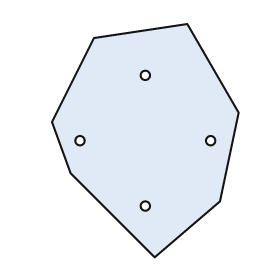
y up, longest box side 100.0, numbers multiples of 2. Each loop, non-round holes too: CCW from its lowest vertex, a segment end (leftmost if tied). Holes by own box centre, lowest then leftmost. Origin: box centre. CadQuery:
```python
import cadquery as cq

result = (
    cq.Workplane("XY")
    .moveTo(4.0, -50.0)
    .lineTo(32.0, -26.0)
    .lineTo(40.0, 12.0)
    .lineTo(18.0, 50.0)
    .lineTo(-22.0, 44.0)
    .lineTo(-40.0, 8.0)
    .lineTo(-32.0, -14.0)
    .close()
    .moveTo(0.0, -28.0)
    .circle(2.0)
    .moveTo(-28.0, 0.0)
    .circle(2.0)
    .moveTo(28.0, 0.0)
    .circle(2.0)
    .moveTo(0.0, 28.0)
    .circle(2.0)
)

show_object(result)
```